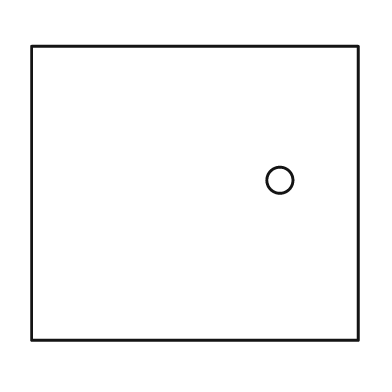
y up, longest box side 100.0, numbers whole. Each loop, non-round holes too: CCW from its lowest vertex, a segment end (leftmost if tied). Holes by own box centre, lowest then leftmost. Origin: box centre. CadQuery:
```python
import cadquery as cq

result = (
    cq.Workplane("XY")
    .moveTo(-50.0, -45.0)
    .lineTo(50.0, -45.0)
    .lineTo(50.0, 45.0)
    .lineTo(-50.0, 45.0)
    .close()
    .moveTo(26.0, 4.0)
    .circle(4.0)
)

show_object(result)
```